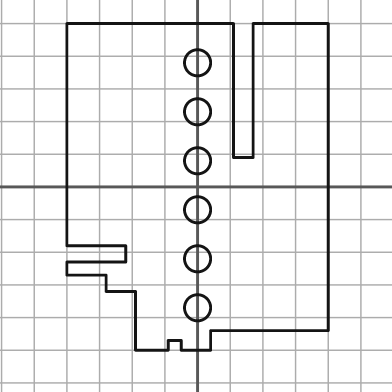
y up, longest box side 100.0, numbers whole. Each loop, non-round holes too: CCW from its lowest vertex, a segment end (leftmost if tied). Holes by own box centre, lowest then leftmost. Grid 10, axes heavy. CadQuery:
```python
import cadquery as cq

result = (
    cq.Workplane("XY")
    .moveTo(-19.0, -50.0)
    .lineTo(-9.0, -50.0)
    .lineTo(-9.0, -47.0)
    .lineTo(-5.0, -47.0)
    .lineTo(-5.0, -50.0)
    .lineTo(4.0, -50.0)
    .lineTo(4.0, -44.0)
    .lineTo(40.0, -44.0)
    .lineTo(40.0, 50.0)
    .lineTo(17.0, 50.0)
    .lineTo(17.0, 9.0)
    .lineTo(11.0, 9.0)
    .lineTo(11.0, 50.0)
    .lineTo(-40.0, 50.0)
    .lineTo(-40.0, -18.0)
    .lineTo(-22.0, -18.0)
    .lineTo(-22.0, -23.0)
    .lineTo(-40.0, -23.0)
    .lineTo(-40.0, -27.0)
    .lineTo(-28.0, -27.0)
    .lineTo(-28.0, -32.0)
    .lineTo(-19.0, -32.0)
    .close()
    .moveTo(0.0, -37.0)
    .circle(4.0)
    .moveTo(0.0, -22.0)
    .circle(4.0)
    .moveTo(0.0, -7.0)
    .circle(4.0)
    .moveTo(0.0, 8.0)
    .circle(4.0)
    .moveTo(0.0, 23.0)
    .circle(4.0)
    .moveTo(0.0, 38.0)
    .circle(4.0)
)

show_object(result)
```